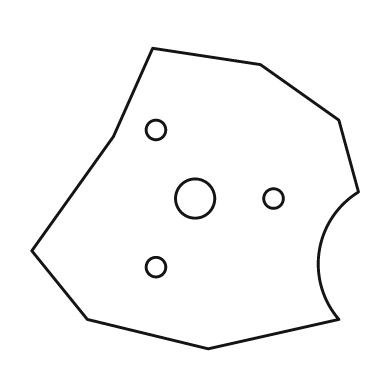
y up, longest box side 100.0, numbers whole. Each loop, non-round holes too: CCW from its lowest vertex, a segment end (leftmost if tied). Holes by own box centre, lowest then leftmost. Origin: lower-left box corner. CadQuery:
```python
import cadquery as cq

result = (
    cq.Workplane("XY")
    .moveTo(54.0, 0.0)
    .lineTo(94.0, 9.0)
    .threePointArc((88.0, 30.0), (100.0, 48.0))
    .lineTo(94.0, 70.0)
    .lineTo(70.0, 87.0)
    .lineTo(37.0, 92.0)
    .lineTo(25.0, 65.0)
    .lineTo(0.0, 30.0)
    .lineTo(17.0, 9.0)
    .close()
    .moveTo(38.0, 25.0)
    .circle(3.0)
    .moveTo(50.0, 46.0)
    .circle(6.0)
    .moveTo(74.0, 46.0)
    .circle(3.0)
    .moveTo(38.0, 67.0)
    .circle(3.0)
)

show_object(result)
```